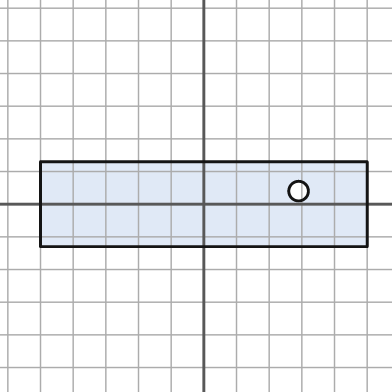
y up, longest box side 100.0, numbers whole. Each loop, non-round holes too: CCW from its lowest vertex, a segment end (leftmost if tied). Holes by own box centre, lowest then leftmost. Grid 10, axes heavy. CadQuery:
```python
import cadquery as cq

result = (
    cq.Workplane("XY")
    .moveTo(-50.0, -13.0)
    .lineTo(50.0, -13.0)
    .lineTo(50.0, 13.0)
    .lineTo(-50.0, 13.0)
    .close()
    .moveTo(29.0, 4.0)
    .circle(3.0)
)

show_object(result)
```